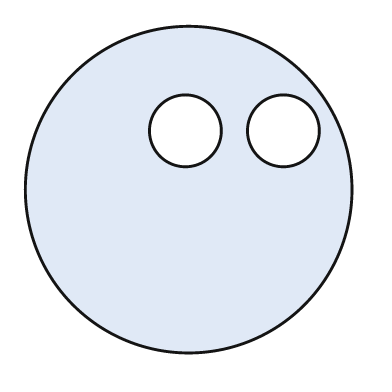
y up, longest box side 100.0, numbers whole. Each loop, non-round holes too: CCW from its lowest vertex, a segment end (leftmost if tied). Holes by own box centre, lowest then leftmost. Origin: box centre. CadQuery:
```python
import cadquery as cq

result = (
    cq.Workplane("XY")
    .moveTo(0.0, 0.0)
    .circle(50.0)
    .moveTo(-1.0, 18.0)
    .circle(11.0)
    .moveTo(29.0, 18.0)
    .circle(11.0)
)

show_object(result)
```